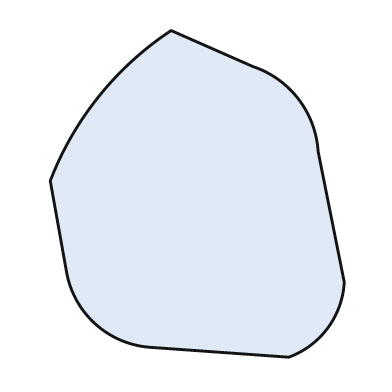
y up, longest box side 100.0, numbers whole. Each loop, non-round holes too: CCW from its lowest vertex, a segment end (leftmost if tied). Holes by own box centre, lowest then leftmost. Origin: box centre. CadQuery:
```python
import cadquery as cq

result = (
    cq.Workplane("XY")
    .moveTo(28.0, -50.0)
    .threePointArc((40.0, -41.0), (45.0, -27.0))
    .lineTo(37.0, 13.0)
    .threePointArc((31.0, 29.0), (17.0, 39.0))
    .lineTo(-8.0, 50.0)
    .threePointArc((-30.0, 30.0), (-45.0, 4.0))
    .lineTo(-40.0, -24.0)
    .threePointArc((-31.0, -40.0), (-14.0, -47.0))
    .close()
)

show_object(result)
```